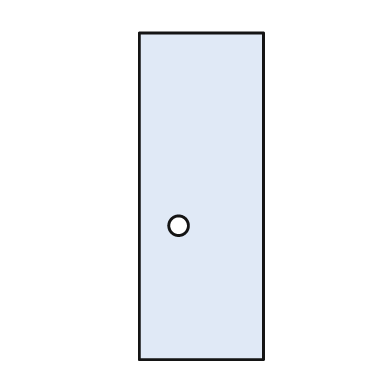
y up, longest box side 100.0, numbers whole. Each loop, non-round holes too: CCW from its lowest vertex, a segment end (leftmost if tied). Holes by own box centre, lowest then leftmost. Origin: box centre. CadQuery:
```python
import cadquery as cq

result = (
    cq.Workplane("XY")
    .moveTo(-19.0, -50.0)
    .lineTo(19.0, -50.0)
    .lineTo(19.0, 50.0)
    .lineTo(-19.0, 50.0)
    .close()
    .moveTo(-7.0, -9.0)
    .circle(3.0)
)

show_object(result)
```